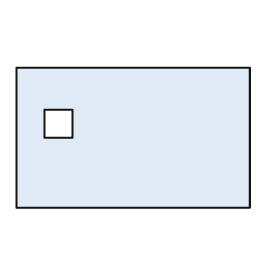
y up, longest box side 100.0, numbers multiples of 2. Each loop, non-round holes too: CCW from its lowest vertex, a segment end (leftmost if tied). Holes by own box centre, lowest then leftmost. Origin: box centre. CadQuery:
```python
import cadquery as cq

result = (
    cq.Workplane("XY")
    .moveTo(-50.0, -30.0)
    .lineTo(50.0, -30.0)
    .lineTo(50.0, 30.0)
    .lineTo(-50.0, 30.0)
    .close()
    .moveTo(-38.0, 0.0)
    .lineTo(-26.0, 0.0)
    .lineTo(-26.0, 12.0)
    .lineTo(-38.0, 12.0)
    .close()
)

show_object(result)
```